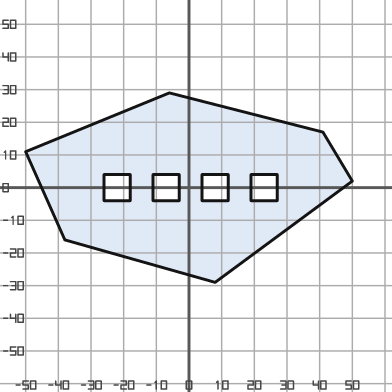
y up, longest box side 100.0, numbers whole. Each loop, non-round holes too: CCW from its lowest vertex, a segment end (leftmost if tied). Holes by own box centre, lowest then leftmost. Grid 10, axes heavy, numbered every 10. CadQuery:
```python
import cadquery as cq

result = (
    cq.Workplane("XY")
    .moveTo(8.0, -29.0)
    .lineTo(50.0, 2.0)
    .lineTo(41.0, 17.0)
    .lineTo(-6.0, 29.0)
    .lineTo(-50.0, 11.0)
    .lineTo(-38.0, -16.0)
    .close()
    .moveTo(-26.0, -4.0)
    .lineTo(-18.0, -4.0)
    .lineTo(-18.0, 4.0)
    .lineTo(-26.0, 4.0)
    .close()
    .moveTo(-11.0, -4.0)
    .lineTo(-3.0, -4.0)
    .lineTo(-3.0, 4.0)
    .lineTo(-11.0, 4.0)
    .close()
    .moveTo(4.0, -4.0)
    .lineTo(12.0, -4.0)
    .lineTo(12.0, 4.0)
    .lineTo(4.0, 4.0)
    .close()
    .moveTo(19.0, -4.0)
    .lineTo(27.0, -4.0)
    .lineTo(27.0, 4.0)
    .lineTo(19.0, 4.0)
    .close()
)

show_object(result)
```